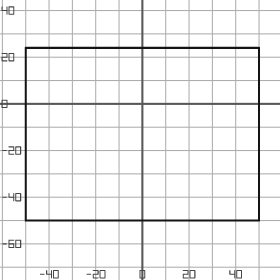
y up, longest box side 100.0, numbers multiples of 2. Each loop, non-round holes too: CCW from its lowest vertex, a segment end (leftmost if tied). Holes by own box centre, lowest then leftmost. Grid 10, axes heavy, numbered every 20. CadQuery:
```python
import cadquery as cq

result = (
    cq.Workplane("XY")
    .moveTo(-50.0, -50.0)
    .lineTo(50.0, -50.0)
    .lineTo(50.0, 24.0)
    .lineTo(-50.0, 24.0)
    .close()
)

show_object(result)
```